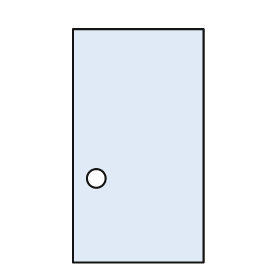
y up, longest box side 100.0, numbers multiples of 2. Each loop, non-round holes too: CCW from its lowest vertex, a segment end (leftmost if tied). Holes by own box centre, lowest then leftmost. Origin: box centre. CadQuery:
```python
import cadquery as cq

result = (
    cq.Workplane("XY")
    .moveTo(-28.0, -50.0)
    .lineTo(28.0, -50.0)
    .lineTo(28.0, 50.0)
    .lineTo(-28.0, 50.0)
    .close()
    .moveTo(-18.0, -14.0)
    .circle(4.0)
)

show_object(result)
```